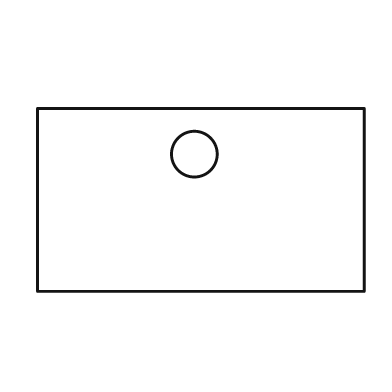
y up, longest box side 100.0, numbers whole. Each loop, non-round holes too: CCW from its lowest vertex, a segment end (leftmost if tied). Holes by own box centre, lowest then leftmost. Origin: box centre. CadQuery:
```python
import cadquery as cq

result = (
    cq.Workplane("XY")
    .moveTo(-50.0, -28.0)
    .lineTo(50.0, -28.0)
    .lineTo(50.0, 28.0)
    .lineTo(-50.0, 28.0)
    .close()
    .moveTo(-2.0, 14.0)
    .circle(7.0)
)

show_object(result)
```